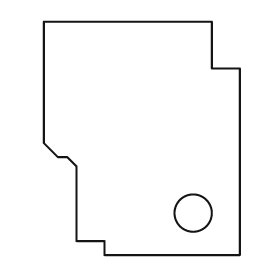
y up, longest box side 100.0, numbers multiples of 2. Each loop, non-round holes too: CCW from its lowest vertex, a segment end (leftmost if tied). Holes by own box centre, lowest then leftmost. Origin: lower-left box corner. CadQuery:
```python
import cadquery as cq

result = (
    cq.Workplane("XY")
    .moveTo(26.0, 0.0)
    .lineTo(84.0, 0.0)
    .lineTo(84.0, 80.0)
    .lineTo(72.0, 80.0)
    .lineTo(72.0, 100.0)
    .lineTo(0.0, 100.0)
    .lineTo(0.0, 48.0)
    .lineTo(6.0, 42.0)
    .lineTo(10.0, 42.0)
    .lineTo(14.0, 38.0)
    .lineTo(14.0, 6.0)
    .lineTo(26.0, 6.0)
    .close()
    .moveTo(64.0, 18.0)
    .circle(8.0)
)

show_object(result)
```